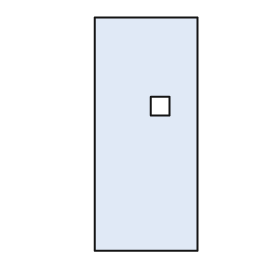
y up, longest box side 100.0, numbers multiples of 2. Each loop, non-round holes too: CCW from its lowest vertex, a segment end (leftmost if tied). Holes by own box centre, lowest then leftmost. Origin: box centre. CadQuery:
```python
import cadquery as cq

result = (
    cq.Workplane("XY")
    .moveTo(-22.0, -50.0)
    .lineTo(22.0, -50.0)
    .lineTo(22.0, 50.0)
    .lineTo(-22.0, 50.0)
    .close()
    .moveTo(2.0, 8.0)
    .lineTo(10.0, 8.0)
    .lineTo(10.0, 16.0)
    .lineTo(2.0, 16.0)
    .close()
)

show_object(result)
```